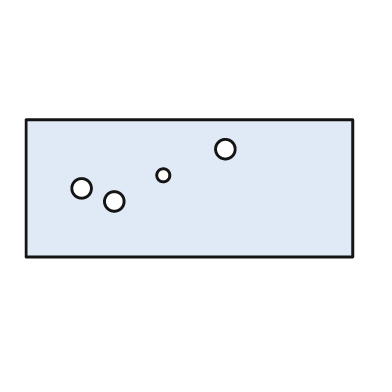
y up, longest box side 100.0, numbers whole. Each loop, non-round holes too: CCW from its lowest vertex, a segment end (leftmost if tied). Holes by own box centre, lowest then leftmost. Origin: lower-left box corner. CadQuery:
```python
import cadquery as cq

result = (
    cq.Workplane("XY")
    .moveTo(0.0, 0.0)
    .lineTo(100.0, 0.0)
    .lineTo(100.0, 42.0)
    .lineTo(0.0, 42.0)
    .close()
    .moveTo(27.0, 17.0)
    .circle(3.0)
    .moveTo(17.0, 21.0)
    .circle(3.0)
    .moveTo(42.0, 25.0)
    .circle(2.0)
    .moveTo(61.0, 33.0)
    .circle(3.0)
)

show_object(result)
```